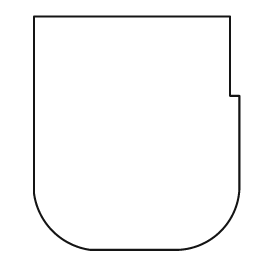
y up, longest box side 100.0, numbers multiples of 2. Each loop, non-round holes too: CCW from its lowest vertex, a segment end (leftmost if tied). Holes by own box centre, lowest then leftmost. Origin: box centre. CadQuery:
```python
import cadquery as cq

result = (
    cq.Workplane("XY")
    .moveTo(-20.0, -50.0)
    .lineTo(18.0, -50.0)
    .threePointArc((36.0, -42.0), (44.0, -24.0))
    .lineTo(44.0, 16.0)
    .lineTo(40.0, 16.0)
    .lineTo(40.0, 50.0)
    .lineTo(-44.0, 50.0)
    .lineTo(-44.0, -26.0)
    .threePointArc((-36.0, -42.0), (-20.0, -50.0))
    .close()
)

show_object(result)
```